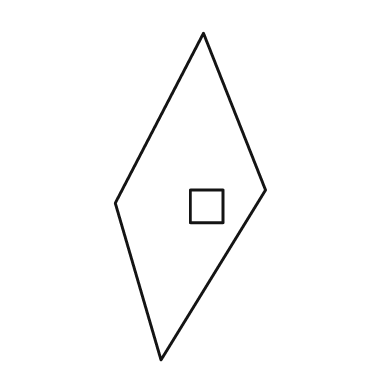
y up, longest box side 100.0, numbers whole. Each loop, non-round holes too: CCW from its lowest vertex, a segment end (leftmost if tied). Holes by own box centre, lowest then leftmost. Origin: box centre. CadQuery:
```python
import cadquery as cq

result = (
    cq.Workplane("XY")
    .moveTo(-9.0, -50.0)
    .lineTo(23.0, 2.0)
    .lineTo(4.0, 50.0)
    .lineTo(-23.0, -2.0)
    .close()
    .moveTo(0.0, -8.0)
    .lineTo(10.0, -8.0)
    .lineTo(10.0, 2.0)
    .lineTo(0.0, 2.0)
    .close()
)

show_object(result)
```